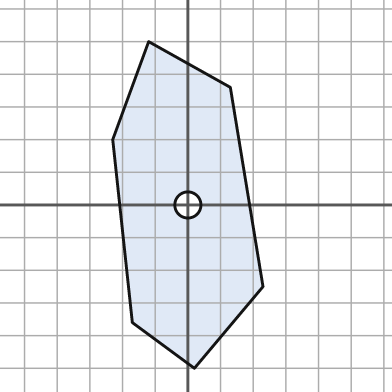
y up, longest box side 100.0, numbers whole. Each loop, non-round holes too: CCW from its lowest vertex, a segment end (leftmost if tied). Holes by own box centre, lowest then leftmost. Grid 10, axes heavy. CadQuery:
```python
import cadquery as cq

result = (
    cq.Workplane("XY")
    .moveTo(2.0, -50.0)
    .lineTo(23.0, -25.0)
    .lineTo(13.0, 36.0)
    .lineTo(-12.0, 50.0)
    .lineTo(-23.0, 20.0)
    .lineTo(-17.0, -36.0)
    .close()
    .moveTo(0.0, 0.0)
    .circle(4.0)
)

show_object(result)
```